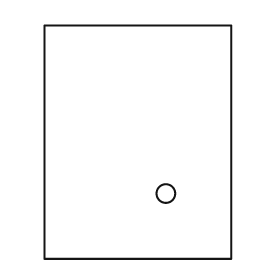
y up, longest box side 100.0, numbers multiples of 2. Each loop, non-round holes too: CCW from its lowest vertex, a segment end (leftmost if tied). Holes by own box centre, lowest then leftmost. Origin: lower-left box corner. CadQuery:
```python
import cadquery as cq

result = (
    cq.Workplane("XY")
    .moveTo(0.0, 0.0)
    .lineTo(80.0, 0.0)
    .lineTo(80.0, 100.0)
    .lineTo(0.0, 100.0)
    .close()
    .moveTo(52.0, 28.0)
    .circle(4.0)
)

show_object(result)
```